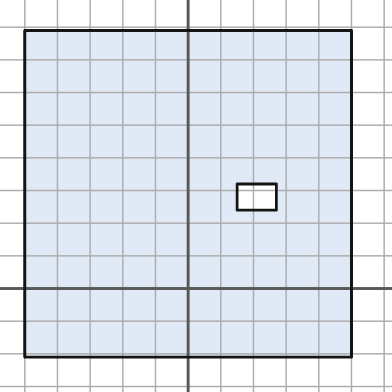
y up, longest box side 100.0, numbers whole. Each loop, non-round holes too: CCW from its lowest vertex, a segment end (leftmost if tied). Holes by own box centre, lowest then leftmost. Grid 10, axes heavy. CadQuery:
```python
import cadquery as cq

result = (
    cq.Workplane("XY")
    .moveTo(-50.0, -21.0)
    .lineTo(50.0, -21.0)
    .lineTo(50.0, 79.0)
    .lineTo(-50.0, 79.0)
    .close()
    .moveTo(15.0, 24.0)
    .lineTo(27.0, 24.0)
    .lineTo(27.0, 32.0)
    .lineTo(15.0, 32.0)
    .close()
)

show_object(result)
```